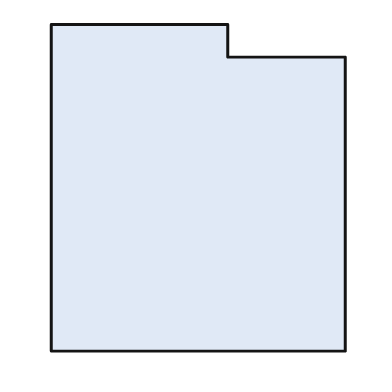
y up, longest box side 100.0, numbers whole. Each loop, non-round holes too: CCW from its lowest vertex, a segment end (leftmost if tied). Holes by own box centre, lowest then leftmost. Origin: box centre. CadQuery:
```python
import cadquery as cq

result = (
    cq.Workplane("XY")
    .moveTo(-45.0, -50.0)
    .lineTo(45.0, -50.0)
    .lineTo(45.0, 40.0)
    .lineTo(9.0, 40.0)
    .lineTo(9.0, 50.0)
    .lineTo(-45.0, 50.0)
    .close()
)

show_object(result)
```